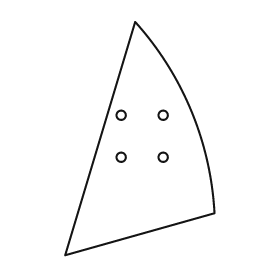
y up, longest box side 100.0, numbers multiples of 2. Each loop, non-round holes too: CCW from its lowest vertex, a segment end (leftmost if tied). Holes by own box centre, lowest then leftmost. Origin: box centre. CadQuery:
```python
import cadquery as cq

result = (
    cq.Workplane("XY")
    .moveTo(-32.0, -50.0)
    .lineTo(32.0, -32.0)
    .threePointArc((22.0, 12.0), (-2.0, 50.0))
    .close()
    .moveTo(-8.0, -8.0)
    .circle(2.0)
    .moveTo(10.0, -8.0)
    .circle(2.0)
    .moveTo(-8.0, 10.0)
    .circle(2.0)
    .moveTo(10.0, 10.0)
    .circle(2.0)
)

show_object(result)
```